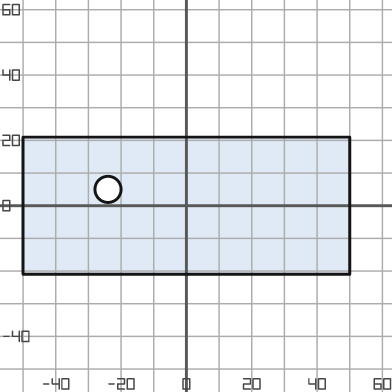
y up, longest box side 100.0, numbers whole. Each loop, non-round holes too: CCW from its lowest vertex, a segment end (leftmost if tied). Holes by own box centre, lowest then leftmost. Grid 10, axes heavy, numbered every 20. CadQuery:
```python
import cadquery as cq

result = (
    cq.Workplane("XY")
    .moveTo(-50.0, -21.0)
    .lineTo(50.0, -21.0)
    .lineTo(50.0, 21.0)
    .lineTo(-50.0, 21.0)
    .close()
    .moveTo(-24.0, 5.0)
    .circle(4.0)
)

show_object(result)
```